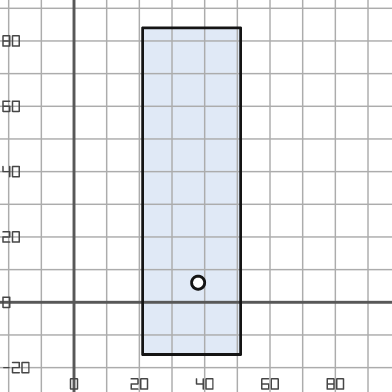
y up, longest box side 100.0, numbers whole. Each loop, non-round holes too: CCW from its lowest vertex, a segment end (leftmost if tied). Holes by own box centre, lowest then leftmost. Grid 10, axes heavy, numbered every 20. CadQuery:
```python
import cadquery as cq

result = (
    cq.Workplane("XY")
    .moveTo(21.0, -16.0)
    .lineTo(51.0, -16.0)
    .lineTo(51.0, 84.0)
    .lineTo(21.0, 84.0)
    .close()
    .moveTo(38.0, 6.0)
    .circle(2.0)
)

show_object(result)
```